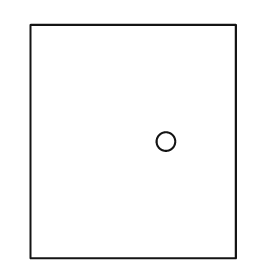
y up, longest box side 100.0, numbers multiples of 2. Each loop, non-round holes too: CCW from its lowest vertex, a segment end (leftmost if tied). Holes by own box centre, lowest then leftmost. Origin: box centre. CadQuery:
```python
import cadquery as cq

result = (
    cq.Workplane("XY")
    .moveTo(-44.0, -50.0)
    .lineTo(44.0, -50.0)
    .lineTo(44.0, 50.0)
    .lineTo(-44.0, 50.0)
    .close()
    .moveTo(14.0, 0.0)
    .circle(4.0)
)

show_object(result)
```